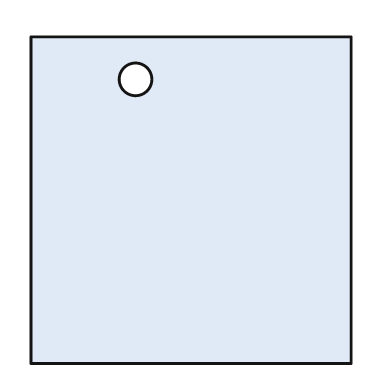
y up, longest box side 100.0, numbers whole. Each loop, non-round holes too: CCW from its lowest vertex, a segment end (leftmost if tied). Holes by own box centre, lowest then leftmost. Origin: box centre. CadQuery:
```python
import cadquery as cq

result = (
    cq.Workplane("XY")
    .moveTo(-49.0, -50.0)
    .lineTo(49.0, -50.0)
    .lineTo(49.0, 50.0)
    .lineTo(-49.0, 50.0)
    .close()
    .moveTo(-17.0, 37.0)
    .circle(5.0)
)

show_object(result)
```